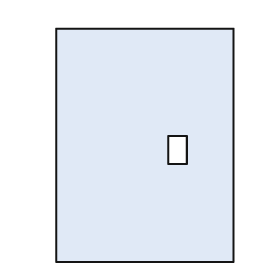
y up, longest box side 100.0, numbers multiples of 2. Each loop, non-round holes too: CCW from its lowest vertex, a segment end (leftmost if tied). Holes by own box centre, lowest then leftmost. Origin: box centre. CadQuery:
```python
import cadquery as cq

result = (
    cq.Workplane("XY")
    .moveTo(-38.0, -50.0)
    .lineTo(38.0, -50.0)
    .lineTo(38.0, 50.0)
    .lineTo(-38.0, 50.0)
    .close()
    .moveTo(10.0, -8.0)
    .lineTo(18.0, -8.0)
    .lineTo(18.0, 4.0)
    .lineTo(10.0, 4.0)
    .close()
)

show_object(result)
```